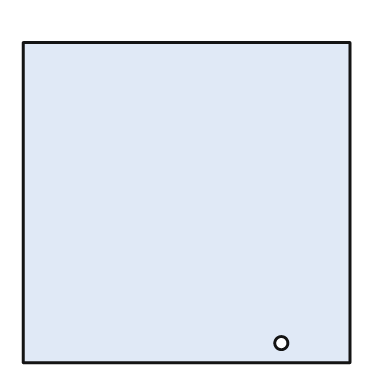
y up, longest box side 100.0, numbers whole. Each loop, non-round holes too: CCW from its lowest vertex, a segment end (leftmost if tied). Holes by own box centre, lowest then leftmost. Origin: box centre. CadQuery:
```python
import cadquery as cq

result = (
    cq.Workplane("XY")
    .moveTo(-50.0, -49.0)
    .lineTo(50.0, -49.0)
    .lineTo(50.0, 49.0)
    .lineTo(-50.0, 49.0)
    .close()
    .moveTo(29.0, -43.0)
    .circle(2.0)
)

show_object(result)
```